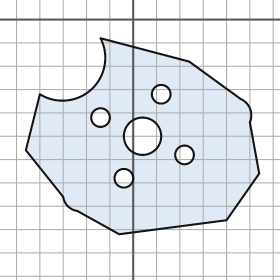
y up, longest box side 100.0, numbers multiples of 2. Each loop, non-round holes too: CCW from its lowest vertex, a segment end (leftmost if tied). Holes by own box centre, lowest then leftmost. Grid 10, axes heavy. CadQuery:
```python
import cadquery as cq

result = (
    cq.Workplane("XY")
    .moveTo(-6.0, -92.0)
    .lineTo(40.0, -86.0)
    .lineTo(54.0, -66.0)
    .lineTo(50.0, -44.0)
    .threePointArc((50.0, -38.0), (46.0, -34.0))
    .lineTo(24.0, -18.0)
    .lineTo(-14.0, -8.0)
    .threePointArc((-18.0, -30.0), (-40.0, -32.0))
    .lineTo(-46.0, -56.0)
    .lineTo(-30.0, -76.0)
    .threePointArc((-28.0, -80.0), (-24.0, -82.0))
    .close()
    .moveTo(-4.0, -68.0)
    .circle(4.0)
    .moveTo(22.0, -58.0)
    .circle(4.0)
    .moveTo(4.0, -50.0)
    .circle(8.0)
    .moveTo(-14.0, -42.0)
    .circle(4.0)
    .moveTo(12.0, -32.0)
    .circle(4.0)
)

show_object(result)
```